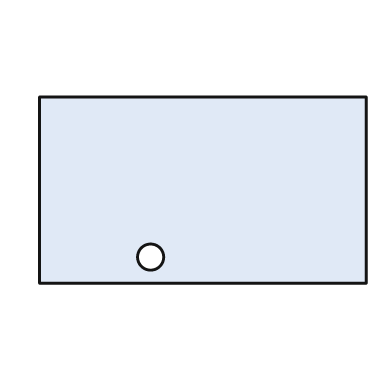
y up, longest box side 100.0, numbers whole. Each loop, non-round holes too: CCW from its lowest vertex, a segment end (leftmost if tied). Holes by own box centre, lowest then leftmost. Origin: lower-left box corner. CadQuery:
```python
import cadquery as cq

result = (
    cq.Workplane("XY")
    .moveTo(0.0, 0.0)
    .lineTo(100.0, 0.0)
    .lineTo(100.0, 57.0)
    .lineTo(0.0, 57.0)
    .close()
    .moveTo(34.0, 8.0)
    .circle(4.0)
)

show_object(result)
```